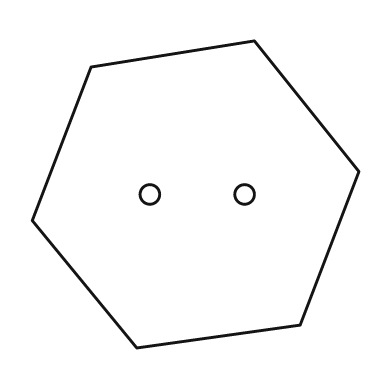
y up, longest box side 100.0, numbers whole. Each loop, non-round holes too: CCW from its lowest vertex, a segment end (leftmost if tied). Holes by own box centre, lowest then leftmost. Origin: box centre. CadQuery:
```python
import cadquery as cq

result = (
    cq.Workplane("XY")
    .moveTo(-18.0, -47.0)
    .lineTo(32.0, -40.0)
    .lineTo(50.0, 7.0)
    .lineTo(18.0, 47.0)
    .lineTo(-32.0, 39.0)
    .lineTo(-50.0, -8.0)
    .close()
    .moveTo(-14.0, 0.0)
    .circle(3.0)
    .moveTo(15.0, 0.0)
    .circle(3.0)
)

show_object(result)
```